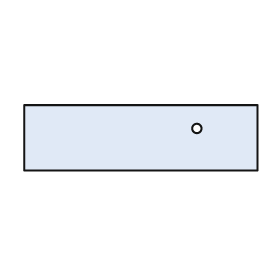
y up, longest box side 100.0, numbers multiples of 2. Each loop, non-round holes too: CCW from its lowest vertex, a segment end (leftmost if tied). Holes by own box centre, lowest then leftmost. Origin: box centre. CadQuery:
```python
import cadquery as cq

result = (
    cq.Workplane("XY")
    .moveTo(-50.0, -14.0)
    .lineTo(50.0, -14.0)
    .lineTo(50.0, 14.0)
    .lineTo(-50.0, 14.0)
    .close()
    .moveTo(24.0, 4.0)
    .circle(2.0)
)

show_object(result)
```